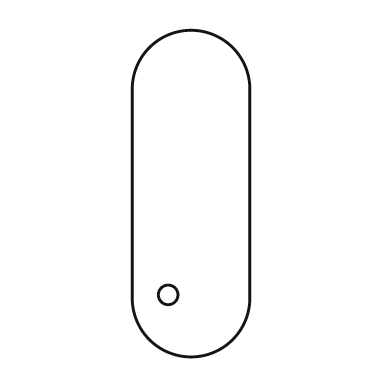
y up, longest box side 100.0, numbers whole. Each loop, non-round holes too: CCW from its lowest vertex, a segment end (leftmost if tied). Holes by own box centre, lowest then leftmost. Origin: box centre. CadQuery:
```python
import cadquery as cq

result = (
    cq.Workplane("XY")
    .moveTo(-18.0, -32.0)
    .threePointArc((0.0, -50.0), (18.0, -32.0))
    .lineTo(18.0, 32.0)
    .threePointArc((0.0, 50.0), (-18.0, 32.0))
    .close()
    .moveTo(-7.0, -31.0)
    .circle(3.0)
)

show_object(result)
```